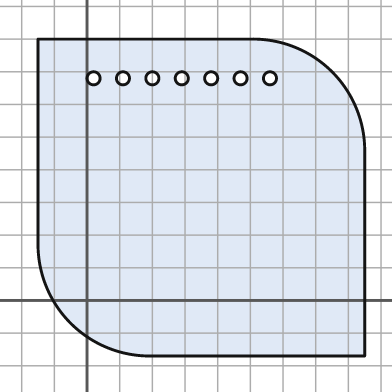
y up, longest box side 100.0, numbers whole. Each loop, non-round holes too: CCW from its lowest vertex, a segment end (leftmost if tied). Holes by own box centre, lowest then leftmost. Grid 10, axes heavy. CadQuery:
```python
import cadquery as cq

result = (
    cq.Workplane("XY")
    .moveTo(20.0, -17.0)
    .lineTo(85.0, -17.0)
    .lineTo(85.0, 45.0)
    .threePointArc((75.0, 70.0), (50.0, 80.0))
    .lineTo(-15.0, 80.0)
    .lineTo(-15.0, 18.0)
    .threePointArc((-5.0, -7.0), (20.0, -17.0))
    .close()
    .moveTo(2.0, 68.0)
    .circle(2.0)
    .moveTo(11.0, 68.0)
    .circle(2.0)
    .moveTo(20.0, 68.0)
    .circle(2.0)
    .moveTo(29.0, 68.0)
    .circle(2.0)
    .moveTo(38.0, 68.0)
    .circle(2.0)
    .moveTo(47.0, 68.0)
    .circle(2.0)
    .moveTo(56.0, 68.0)
    .circle(2.0)
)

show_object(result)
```